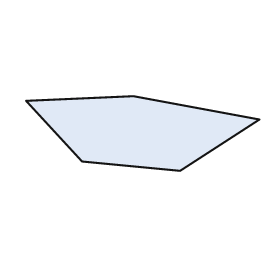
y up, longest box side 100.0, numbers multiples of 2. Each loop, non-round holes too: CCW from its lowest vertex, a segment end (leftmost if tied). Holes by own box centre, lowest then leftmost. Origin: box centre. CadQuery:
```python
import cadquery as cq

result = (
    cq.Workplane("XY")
    .moveTo(16.0, -16.0)
    .lineTo(50.0, 6.0)
    .lineTo(-4.0, 16.0)
    .lineTo(-50.0, 14.0)
    .lineTo(-26.0, -12.0)
    .close()
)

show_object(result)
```